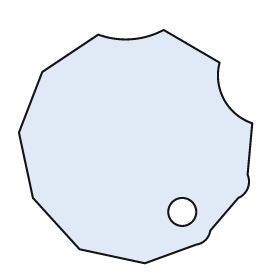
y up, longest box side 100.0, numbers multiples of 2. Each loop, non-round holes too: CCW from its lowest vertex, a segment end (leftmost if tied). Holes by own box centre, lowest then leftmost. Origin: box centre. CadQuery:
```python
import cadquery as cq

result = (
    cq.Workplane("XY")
    .moveTo(4.0, -50.0)
    .lineTo(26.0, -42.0)
    .threePointArc((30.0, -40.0), (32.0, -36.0))
    .lineTo(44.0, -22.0)
    .threePointArc((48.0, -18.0), (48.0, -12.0))
    .lineTo(50.0, 10.0)
    .threePointArc((38.0, 20.0), (36.0, 36.0))
    .lineTo(12.0, 50.0)
    .threePointArc((-2.0, 46.0), (-16.0, 48.0))
    .lineTo(-40.0, 32.0)
    .lineTo(-50.0, 6.0)
    .lineTo(-44.0, -22.0)
    .lineTo(-24.0, -44.0)
    .close()
    .moveTo(20.0, -28.0)
    .circle(6.0)
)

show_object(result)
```